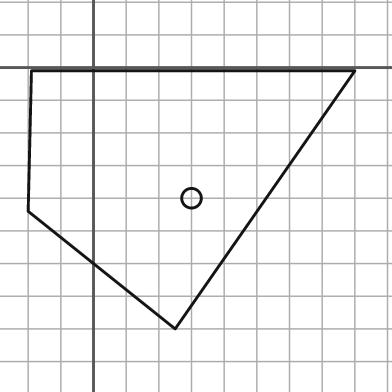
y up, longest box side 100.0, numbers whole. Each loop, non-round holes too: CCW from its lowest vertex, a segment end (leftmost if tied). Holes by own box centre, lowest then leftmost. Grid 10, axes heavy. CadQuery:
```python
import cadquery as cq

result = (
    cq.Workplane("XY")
    .moveTo(25.0, -80.0)
    .lineTo(80.0, -1.0)
    .lineTo(-19.0, -1.0)
    .lineTo(-20.0, -44.0)
    .close()
    .moveTo(30.0, -40.0)
    .circle(3.0)
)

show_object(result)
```